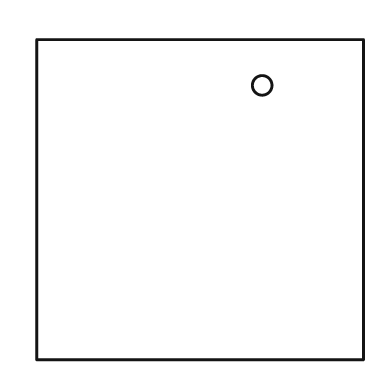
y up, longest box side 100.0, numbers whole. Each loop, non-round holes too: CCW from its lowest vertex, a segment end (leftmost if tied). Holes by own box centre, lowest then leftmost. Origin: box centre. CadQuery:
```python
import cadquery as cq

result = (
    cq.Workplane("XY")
    .moveTo(-50.0, -49.0)
    .lineTo(50.0, -49.0)
    .lineTo(50.0, 49.0)
    .lineTo(-50.0, 49.0)
    .close()
    .moveTo(19.0, 35.0)
    .circle(3.0)
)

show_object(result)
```